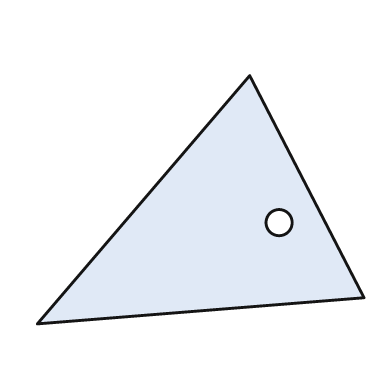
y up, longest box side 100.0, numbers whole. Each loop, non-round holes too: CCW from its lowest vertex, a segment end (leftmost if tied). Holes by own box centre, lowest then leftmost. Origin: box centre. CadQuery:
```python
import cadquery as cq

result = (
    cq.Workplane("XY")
    .moveTo(-50.0, -38.0)
    .lineTo(50.0, -30.0)
    .lineTo(15.0, 38.0)
    .close()
    .moveTo(24.0, -7.0)
    .circle(4.0)
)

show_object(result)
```